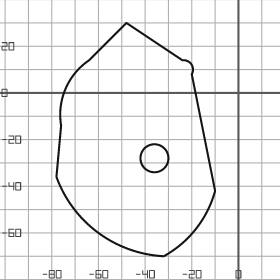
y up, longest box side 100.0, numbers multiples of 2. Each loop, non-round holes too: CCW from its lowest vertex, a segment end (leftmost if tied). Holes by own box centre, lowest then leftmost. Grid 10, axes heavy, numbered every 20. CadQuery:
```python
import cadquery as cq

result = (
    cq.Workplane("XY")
    .moveTo(-32.0, -70.0)
    .threePointArc((-18.0, -58.0), (-10.0, -42.0))
    .lineTo(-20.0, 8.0)
    .threePointArc((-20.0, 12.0), (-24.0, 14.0))
    .lineTo(-48.0, 30.0)
    .lineTo(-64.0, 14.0)
    .threePointArc((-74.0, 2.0), (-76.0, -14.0))
    .lineTo(-78.0, -36.0)
    .threePointArc((-60.0, -60.0), (-32.0, -70.0))
    .close()
    .moveTo(-36.0, -28.0)
    .circle(6.0)
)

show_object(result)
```